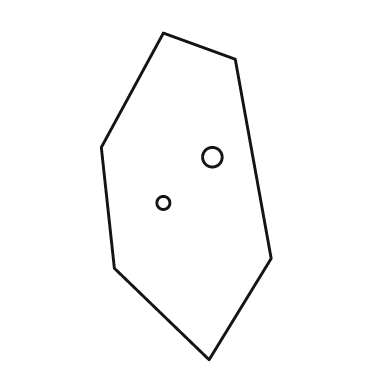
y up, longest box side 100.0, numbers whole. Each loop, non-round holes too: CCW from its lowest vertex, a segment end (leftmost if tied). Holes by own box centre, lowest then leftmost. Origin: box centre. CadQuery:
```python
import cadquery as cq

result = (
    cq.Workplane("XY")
    .moveTo(7.0, -50.0)
    .lineTo(26.0, -19.0)
    .lineTo(15.0, 42.0)
    .lineTo(-7.0, 50.0)
    .lineTo(-26.0, 15.0)
    .lineTo(-22.0, -22.0)
    .close()
    .moveTo(-7.0, -2.0)
    .circle(2.0)
    .moveTo(8.0, 12.0)
    .circle(3.0)
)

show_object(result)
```